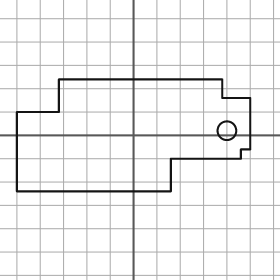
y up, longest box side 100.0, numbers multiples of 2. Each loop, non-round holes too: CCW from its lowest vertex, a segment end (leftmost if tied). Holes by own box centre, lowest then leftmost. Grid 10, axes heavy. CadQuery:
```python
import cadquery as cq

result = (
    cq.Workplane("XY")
    .moveTo(-50.0, -24.0)
    .lineTo(16.0, -24.0)
    .lineTo(16.0, -10.0)
    .lineTo(46.0, -10.0)
    .lineTo(46.0, -6.0)
    .lineTo(50.0, -6.0)
    .lineTo(50.0, 16.0)
    .lineTo(38.0, 16.0)
    .lineTo(38.0, 24.0)
    .lineTo(-32.0, 24.0)
    .lineTo(-32.0, 10.0)
    .lineTo(-50.0, 10.0)
    .close()
    .moveTo(40.0, 2.0)
    .circle(4.0)
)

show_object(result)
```